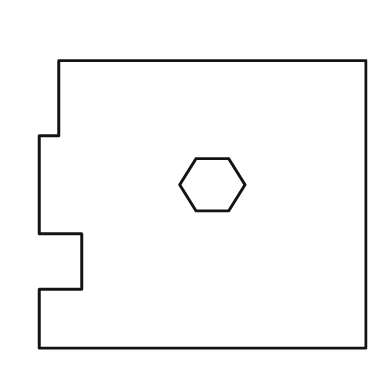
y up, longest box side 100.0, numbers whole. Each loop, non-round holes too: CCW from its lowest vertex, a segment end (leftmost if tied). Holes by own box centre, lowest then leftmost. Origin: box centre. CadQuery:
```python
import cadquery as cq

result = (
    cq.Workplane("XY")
    .moveTo(-50.0, -44.0)
    .lineTo(50.0, -44.0)
    .lineTo(50.0, 44.0)
    .lineTo(-44.0, 44.0)
    .lineTo(-44.0, 21.0)
    .lineTo(-50.0, 21.0)
    .lineTo(-50.0, -9.0)
    .lineTo(-37.0, -9.0)
    .lineTo(-37.0, -26.0)
    .lineTo(-50.0, -26.0)
    .close()
    .moveTo(-2.0, -2.0)
    .lineTo(8.0, -2.0)
    .lineTo(13.0, 6.0)
    .lineTo(8.0, 14.0)
    .lineTo(-2.0, 14.0)
    .lineTo(-7.0, 6.0)
    .close()
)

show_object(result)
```